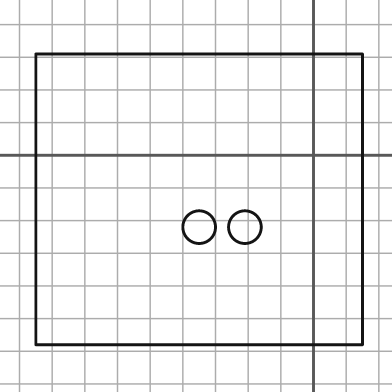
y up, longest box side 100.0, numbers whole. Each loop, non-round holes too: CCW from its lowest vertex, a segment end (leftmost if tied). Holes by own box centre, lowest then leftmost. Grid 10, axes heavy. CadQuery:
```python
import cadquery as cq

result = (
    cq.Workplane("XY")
    .moveTo(-85.0, -58.0)
    .lineTo(15.0, -58.0)
    .lineTo(15.0, 31.0)
    .lineTo(-85.0, 31.0)
    .close()
    .moveTo(-35.0, -22.0)
    .circle(5.0)
    .moveTo(-21.0, -22.0)
    .circle(5.0)
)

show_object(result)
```